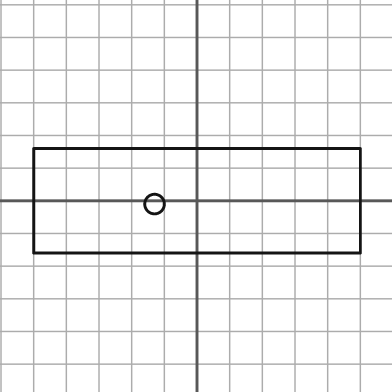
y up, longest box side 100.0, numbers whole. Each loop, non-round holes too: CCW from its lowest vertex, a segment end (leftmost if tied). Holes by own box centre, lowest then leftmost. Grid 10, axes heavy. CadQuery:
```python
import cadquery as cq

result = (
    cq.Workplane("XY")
    .moveTo(-50.0, -16.0)
    .lineTo(50.0, -16.0)
    .lineTo(50.0, 16.0)
    .lineTo(-50.0, 16.0)
    .close()
    .moveTo(-13.0, -1.0)
    .circle(3.0)
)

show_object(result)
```